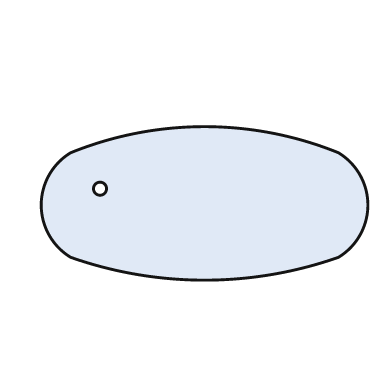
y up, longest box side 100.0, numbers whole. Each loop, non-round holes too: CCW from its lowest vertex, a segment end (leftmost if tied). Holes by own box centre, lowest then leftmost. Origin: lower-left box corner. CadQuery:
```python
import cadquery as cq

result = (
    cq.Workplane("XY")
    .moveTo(9.0, 7.0)
    .threePointArc((50.0, 0.0), (91.0, 7.0))
    .threePointArc((100.0, 23.0), (91.0, 39.0))
    .threePointArc((50.0, 47.0), (9.0, 39.0))
    .threePointArc((0.0, 23.0), (9.0, 7.0))
    .close()
    .moveTo(18.0, 28.0)
    .circle(2.0)
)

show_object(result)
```